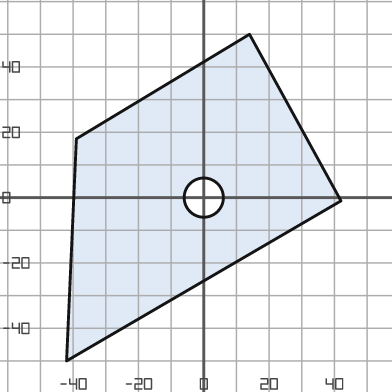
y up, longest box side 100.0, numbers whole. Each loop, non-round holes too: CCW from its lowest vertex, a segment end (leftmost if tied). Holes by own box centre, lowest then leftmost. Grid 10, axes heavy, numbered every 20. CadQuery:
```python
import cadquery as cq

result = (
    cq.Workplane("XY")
    .moveTo(-42.0, -50.0)
    .lineTo(42.0, -1.0)
    .lineTo(14.0, 50.0)
    .lineTo(-39.0, 18.0)
    .close()
    .moveTo(0.0, 0.0)
    .circle(6.0)
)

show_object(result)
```